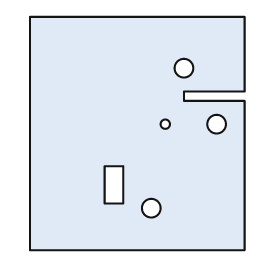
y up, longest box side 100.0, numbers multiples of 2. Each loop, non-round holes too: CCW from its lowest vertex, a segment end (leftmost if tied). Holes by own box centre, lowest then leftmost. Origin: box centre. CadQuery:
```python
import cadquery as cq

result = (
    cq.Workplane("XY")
    .moveTo(-46.0, -50.0)
    .lineTo(46.0, -50.0)
    .lineTo(46.0, 14.0)
    .lineTo(20.0, 14.0)
    .lineTo(20.0, 18.0)
    .lineTo(46.0, 18.0)
    .lineTo(46.0, 50.0)
    .lineTo(-46.0, 50.0)
    .close()
    .moveTo(6.0, -32.0)
    .circle(4.0)
    .moveTo(-14.0, -30.0)
    .lineTo(-6.0, -30.0)
    .lineTo(-6.0, -14.0)
    .lineTo(-14.0, -14.0)
    .close()
    .moveTo(12.0, 4.0)
    .circle(2.0)
    .moveTo(34.0, 4.0)
    .circle(4.0)
    .moveTo(20.0, 28.0)
    .circle(4.0)
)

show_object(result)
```